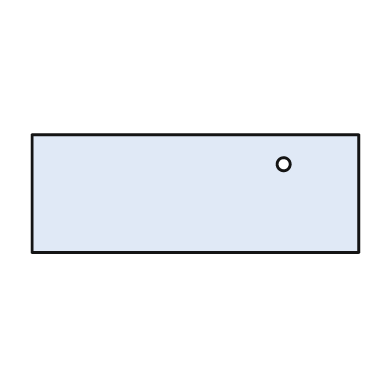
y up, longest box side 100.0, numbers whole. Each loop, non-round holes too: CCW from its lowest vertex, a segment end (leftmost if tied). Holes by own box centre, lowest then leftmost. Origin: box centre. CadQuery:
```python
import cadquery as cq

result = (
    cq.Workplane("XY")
    .moveTo(-50.0, -18.0)
    .lineTo(50.0, -18.0)
    .lineTo(50.0, 18.0)
    .lineTo(-50.0, 18.0)
    .close()
    .moveTo(27.0, 9.0)
    .circle(2.0)
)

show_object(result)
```